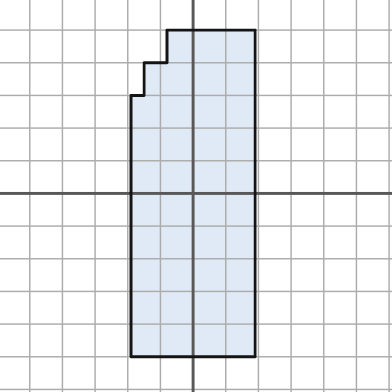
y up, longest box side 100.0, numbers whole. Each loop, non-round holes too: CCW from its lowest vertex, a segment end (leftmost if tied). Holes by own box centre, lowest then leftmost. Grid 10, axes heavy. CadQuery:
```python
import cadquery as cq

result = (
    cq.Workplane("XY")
    .moveTo(-19.0, -50.0)
    .lineTo(19.0, -50.0)
    .lineTo(19.0, 50.0)
    .lineTo(-8.0, 50.0)
    .lineTo(-8.0, 40.0)
    .lineTo(-15.0, 40.0)
    .lineTo(-15.0, 30.0)
    .lineTo(-19.0, 30.0)
    .close()
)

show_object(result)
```